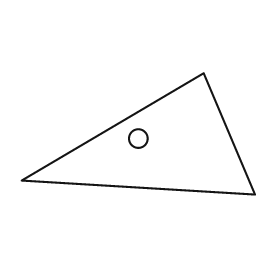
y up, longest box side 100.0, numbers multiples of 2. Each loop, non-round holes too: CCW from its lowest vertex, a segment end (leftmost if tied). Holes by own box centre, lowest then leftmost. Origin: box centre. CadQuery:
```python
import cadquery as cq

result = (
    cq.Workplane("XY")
    .moveTo(50.0, -26.0)
    .lineTo(28.0, 26.0)
    .lineTo(-50.0, -20.0)
    .close()
    .moveTo(0.0, -2.0)
    .circle(4.0)
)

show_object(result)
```